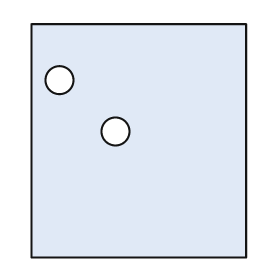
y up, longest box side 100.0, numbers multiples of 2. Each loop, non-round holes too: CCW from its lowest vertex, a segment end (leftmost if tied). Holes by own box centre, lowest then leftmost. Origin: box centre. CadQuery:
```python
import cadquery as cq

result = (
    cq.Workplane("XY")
    .moveTo(-46.0, -50.0)
    .lineTo(46.0, -50.0)
    .lineTo(46.0, 50.0)
    .lineTo(-46.0, 50.0)
    .close()
    .moveTo(-10.0, 4.0)
    .circle(6.0)
    .moveTo(-34.0, 26.0)
    .circle(6.0)
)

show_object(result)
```